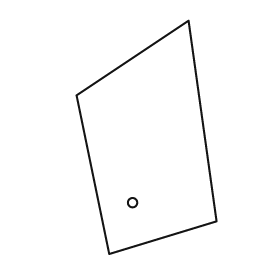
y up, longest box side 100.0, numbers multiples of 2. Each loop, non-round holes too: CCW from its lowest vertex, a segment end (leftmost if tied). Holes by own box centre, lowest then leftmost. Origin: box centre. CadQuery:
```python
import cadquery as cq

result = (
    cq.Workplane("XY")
    .moveTo(-16.0, -50.0)
    .lineTo(30.0, -36.0)
    .lineTo(18.0, 50.0)
    .lineTo(-30.0, 18.0)
    .close()
    .moveTo(-6.0, -28.0)
    .circle(2.0)
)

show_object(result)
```